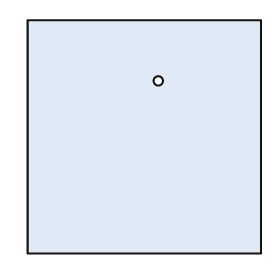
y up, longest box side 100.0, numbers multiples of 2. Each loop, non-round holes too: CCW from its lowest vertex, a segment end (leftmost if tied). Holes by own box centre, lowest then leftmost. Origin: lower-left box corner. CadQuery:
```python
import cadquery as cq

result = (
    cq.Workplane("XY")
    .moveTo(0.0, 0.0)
    .lineTo(100.0, 0.0)
    .lineTo(100.0, 100.0)
    .lineTo(0.0, 100.0)
    .close()
    .moveTo(56.0, 74.0)
    .circle(2.0)
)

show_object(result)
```